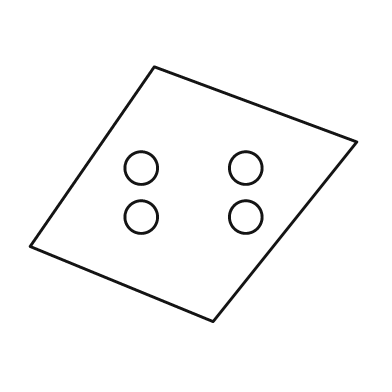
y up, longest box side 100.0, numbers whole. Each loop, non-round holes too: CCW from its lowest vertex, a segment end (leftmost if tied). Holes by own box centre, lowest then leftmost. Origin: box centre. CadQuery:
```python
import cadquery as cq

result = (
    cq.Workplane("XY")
    .moveTo(6.0, -39.0)
    .lineTo(50.0, 16.0)
    .lineTo(-12.0, 39.0)
    .lineTo(-50.0, -16.0)
    .close()
    .moveTo(-16.0, -7.0)
    .circle(5.0)
    .moveTo(16.0, -7.0)
    .circle(5.0)
    .moveTo(-16.0, 8.0)
    .circle(5.0)
    .moveTo(16.0, 8.0)
    .circle(5.0)
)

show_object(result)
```